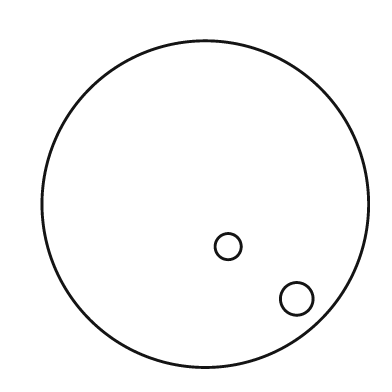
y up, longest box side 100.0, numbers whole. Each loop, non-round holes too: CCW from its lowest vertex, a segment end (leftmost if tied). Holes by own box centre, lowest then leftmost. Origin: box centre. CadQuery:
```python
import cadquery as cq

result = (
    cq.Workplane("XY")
    .moveTo(0.0, 0.0)
    .circle(50.0)
    .moveTo(28.0, -29.0)
    .circle(5.0)
    .moveTo(7.0, -13.0)
    .circle(4.0)
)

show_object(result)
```